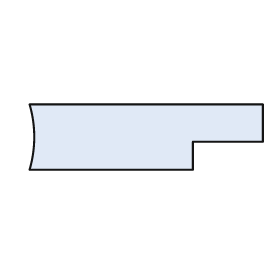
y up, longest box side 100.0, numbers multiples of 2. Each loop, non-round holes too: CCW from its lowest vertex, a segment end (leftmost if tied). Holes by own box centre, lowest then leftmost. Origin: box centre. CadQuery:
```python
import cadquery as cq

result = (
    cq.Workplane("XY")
    .moveTo(-50.0, -14.0)
    .lineTo(20.0, -14.0)
    .lineTo(20.0, -2.0)
    .lineTo(50.0, -2.0)
    .lineTo(50.0, 14.0)
    .lineTo(-50.0, 14.0)
    .threePointArc((-48.0, 0.0), (-50.0, -14.0))
    .close()
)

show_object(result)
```